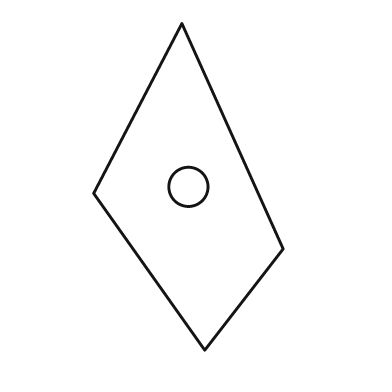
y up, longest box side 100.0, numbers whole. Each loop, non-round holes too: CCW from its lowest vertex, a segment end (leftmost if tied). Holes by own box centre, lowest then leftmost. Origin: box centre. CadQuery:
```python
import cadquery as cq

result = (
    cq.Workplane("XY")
    .moveTo(5.0, -50.0)
    .lineTo(29.0, -19.0)
    .lineTo(-2.0, 50.0)
    .lineTo(-29.0, -2.0)
    .close()
    .moveTo(0.0, 0.0)
    .circle(6.0)
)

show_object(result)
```